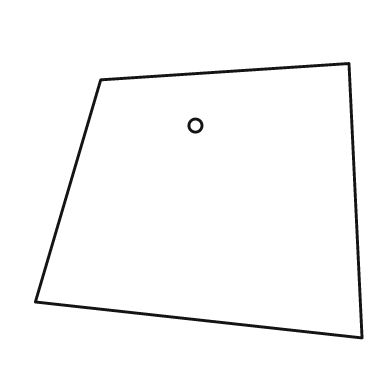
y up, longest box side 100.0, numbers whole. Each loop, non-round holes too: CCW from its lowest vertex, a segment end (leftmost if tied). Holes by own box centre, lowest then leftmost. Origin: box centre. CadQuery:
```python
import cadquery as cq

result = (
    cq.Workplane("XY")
    .moveTo(50.0, -42.0)
    .lineTo(46.0, 42.0)
    .lineTo(-30.0, 37.0)
    .lineTo(-50.0, -31.0)
    .close()
    .moveTo(-1.0, 23.0)
    .circle(2.0)
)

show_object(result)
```